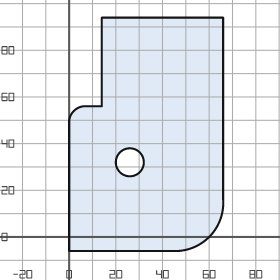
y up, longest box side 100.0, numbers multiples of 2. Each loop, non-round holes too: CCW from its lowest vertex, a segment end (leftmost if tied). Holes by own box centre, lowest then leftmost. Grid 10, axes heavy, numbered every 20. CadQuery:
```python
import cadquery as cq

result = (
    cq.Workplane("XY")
    .moveTo(0.0, -6.0)
    .lineTo(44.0, -6.0)
    .threePointArc((60.0, 0.0), (66.0, 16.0))
    .lineTo(66.0, 94.0)
    .lineTo(14.0, 94.0)
    .lineTo(14.0, 56.0)
    .lineTo(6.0, 56.0)
    .threePointArc((2.0, 54.0), (0.0, 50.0))
    .close()
    .moveTo(26.0, 32.0)
    .circle(6.0)
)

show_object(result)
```